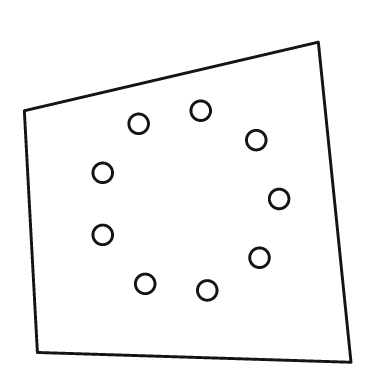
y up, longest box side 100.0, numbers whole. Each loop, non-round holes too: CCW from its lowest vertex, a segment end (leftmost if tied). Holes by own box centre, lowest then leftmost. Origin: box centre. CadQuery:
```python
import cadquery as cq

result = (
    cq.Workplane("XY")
    .moveTo(50.0, -49.0)
    .lineTo(40.0, 49.0)
    .lineTo(-50.0, 28.0)
    .lineTo(-46.0, -46.0)
    .close()
    .moveTo(6.0, -27.0)
    .circle(3.0)
    .moveTo(-13.0, -25.0)
    .circle(3.0)
    .moveTo(22.0, -17.0)
    .circle(3.0)
    .moveTo(-26.0, -10.0)
    .circle(3.0)
    .moveTo(28.0, 1.0)
    .circle(3.0)
    .moveTo(-26.0, 9.0)
    .circle(3.0)
    .moveTo(21.0, 19.0)
    .circle(3.0)
    .moveTo(-15.0, 24.0)
    .circle(3.0)
    .moveTo(4.0, 28.0)
    .circle(3.0)
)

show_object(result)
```